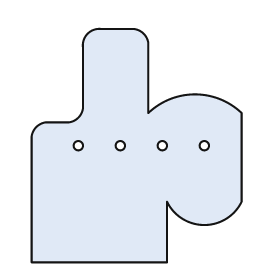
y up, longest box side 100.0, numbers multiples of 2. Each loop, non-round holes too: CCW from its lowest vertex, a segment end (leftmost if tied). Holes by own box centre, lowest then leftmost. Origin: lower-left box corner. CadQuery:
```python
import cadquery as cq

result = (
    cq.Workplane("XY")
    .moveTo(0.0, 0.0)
    .lineTo(58.0, 0.0)
    .lineTo(58.0, 26.0)
    .threePointArc((74.0, 16.0), (90.0, 26.0))
    .lineTo(90.0, 64.0)
    .threePointArc((70.0, 72.0), (50.0, 64.0))
    .lineTo(50.0, 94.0)
    .threePointArc((48.0, 98.0), (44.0, 100.0))
    .lineTo(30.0, 100.0)
    .threePointArc((24.0, 98.0), (22.0, 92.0))
    .lineTo(22.0, 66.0)
    .threePointArc((20.0, 62.0), (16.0, 60.0))
    .lineTo(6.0, 60.0)
    .threePointArc((2.0, 58.0), (0.0, 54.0))
    .close()
    .moveTo(20.0, 50.0)
    .circle(2.0)
    .moveTo(38.0, 50.0)
    .circle(2.0)
    .moveTo(56.0, 50.0)
    .circle(2.0)
    .moveTo(74.0, 50.0)
    .circle(2.0)
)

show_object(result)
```